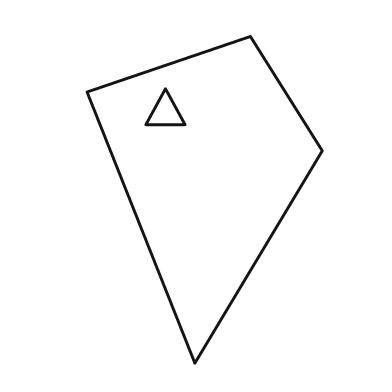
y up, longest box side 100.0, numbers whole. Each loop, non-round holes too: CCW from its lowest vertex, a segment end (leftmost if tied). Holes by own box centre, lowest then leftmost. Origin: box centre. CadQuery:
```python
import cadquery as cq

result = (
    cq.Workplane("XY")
    .moveTo(-3.0, -50.0)
    .lineTo(36.0, 15.0)
    .lineTo(14.0, 50.0)
    .lineTo(-36.0, 33.0)
    .close()
    .moveTo(-18.0, 23.0)
    .lineTo(-6.0, 23.0)
    .lineTo(-12.0, 34.0)
    .close()
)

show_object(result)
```